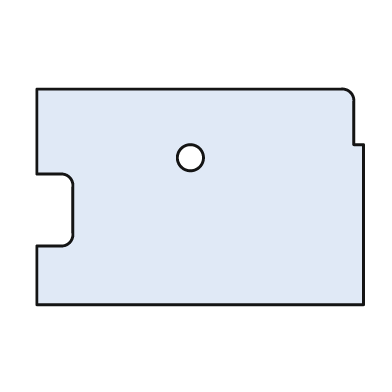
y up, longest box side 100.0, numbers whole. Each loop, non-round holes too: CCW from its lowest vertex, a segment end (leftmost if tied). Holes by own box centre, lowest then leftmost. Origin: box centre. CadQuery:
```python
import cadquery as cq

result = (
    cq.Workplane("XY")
    .moveTo(-50.0, -33.0)
    .lineTo(50.0, -33.0)
    .lineTo(50.0, 16.0)
    .lineTo(47.0, 16.0)
    .lineTo(47.0, 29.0)
    .threePointArc((46.0, 32.0), (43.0, 33.0))
    .lineTo(-50.0, 33.0)
    .lineTo(-50.0, 7.0)
    .lineTo(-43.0, 7.0)
    .threePointArc((-40.0, 6.0), (-39.0, 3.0))
    .lineTo(-39.0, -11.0)
    .threePointArc((-40.0, -14.0), (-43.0, -15.0))
    .lineTo(-50.0, -15.0)
    .close()
    .moveTo(-3.0, 12.0)
    .circle(4.0)
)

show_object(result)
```